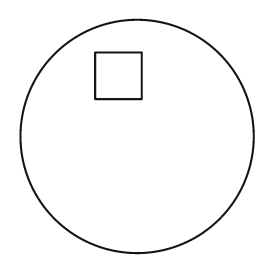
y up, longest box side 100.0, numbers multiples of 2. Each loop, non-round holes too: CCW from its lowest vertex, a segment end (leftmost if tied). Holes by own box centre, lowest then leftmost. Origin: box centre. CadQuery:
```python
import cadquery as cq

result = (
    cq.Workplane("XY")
    .moveTo(0.0, 0.0)
    .circle(50.0)
    .moveTo(-18.0, 16.0)
    .lineTo(2.0, 16.0)
    .lineTo(2.0, 36.0)
    .lineTo(-18.0, 36.0)
    .close()
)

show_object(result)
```